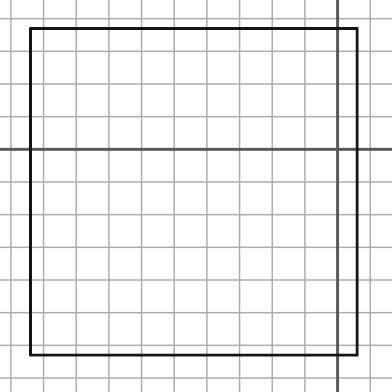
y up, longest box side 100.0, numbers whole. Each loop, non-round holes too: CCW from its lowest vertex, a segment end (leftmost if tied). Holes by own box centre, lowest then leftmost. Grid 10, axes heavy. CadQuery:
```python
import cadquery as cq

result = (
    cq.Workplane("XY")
    .moveTo(-94.0, -63.0)
    .lineTo(6.0, -63.0)
    .lineTo(6.0, 37.0)
    .lineTo(-94.0, 37.0)
    .close()
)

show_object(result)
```